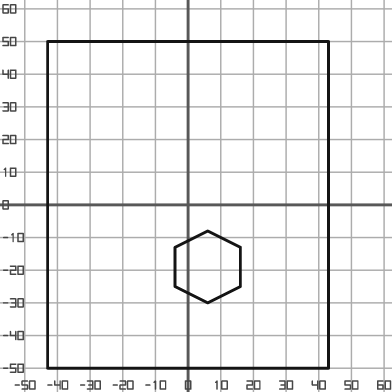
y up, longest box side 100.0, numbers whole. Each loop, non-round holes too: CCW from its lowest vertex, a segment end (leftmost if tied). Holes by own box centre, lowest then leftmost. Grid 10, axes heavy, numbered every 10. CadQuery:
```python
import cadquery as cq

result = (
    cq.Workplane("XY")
    .moveTo(-43.0, -50.0)
    .lineTo(43.0, -50.0)
    .lineTo(43.0, 50.0)
    .lineTo(-43.0, 50.0)
    .close()
    .moveTo(6.0, -30.0)
    .lineTo(16.0, -25.0)
    .lineTo(16.0, -13.0)
    .lineTo(6.0, -8.0)
    .lineTo(-4.0, -13.0)
    .lineTo(-4.0, -25.0)
    .close()
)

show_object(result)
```